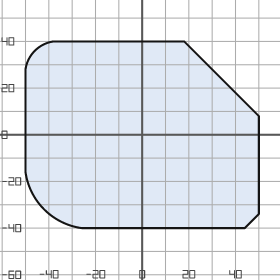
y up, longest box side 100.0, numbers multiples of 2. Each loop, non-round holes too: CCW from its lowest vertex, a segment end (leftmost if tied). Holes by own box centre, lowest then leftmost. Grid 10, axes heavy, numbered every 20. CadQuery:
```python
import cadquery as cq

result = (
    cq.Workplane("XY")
    .moveTo(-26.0, -40.0)
    .lineTo(44.0, -40.0)
    .lineTo(50.0, -34.0)
    .lineTo(50.0, 8.0)
    .lineTo(18.0, 40.0)
    .lineTo(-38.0, 40.0)
    .threePointArc((-46.0, 36.0), (-50.0, 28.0))
    .lineTo(-50.0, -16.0)
    .threePointArc((-42.0, -32.0), (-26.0, -40.0))
    .close()
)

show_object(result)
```